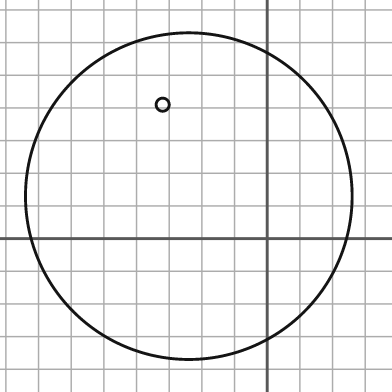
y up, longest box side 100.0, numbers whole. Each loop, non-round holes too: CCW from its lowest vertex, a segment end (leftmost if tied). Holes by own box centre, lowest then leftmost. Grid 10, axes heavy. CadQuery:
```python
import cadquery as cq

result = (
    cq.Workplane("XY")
    .moveTo(-24.0, 13.0)
    .circle(50.0)
    .moveTo(-32.0, 41.0)
    .circle(2.0)
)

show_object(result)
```